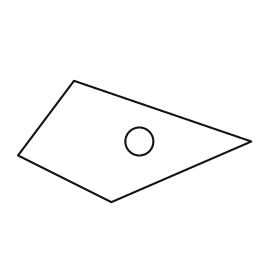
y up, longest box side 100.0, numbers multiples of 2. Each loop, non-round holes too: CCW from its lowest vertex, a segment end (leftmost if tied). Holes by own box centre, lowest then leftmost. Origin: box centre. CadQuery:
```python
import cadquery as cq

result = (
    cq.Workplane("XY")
    .moveTo(-10.0, -26.0)
    .lineTo(50.0, 0.0)
    .lineTo(-26.0, 26.0)
    .lineTo(-50.0, -6.0)
    .close()
    .moveTo(2.0, 0.0)
    .circle(6.0)
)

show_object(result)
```